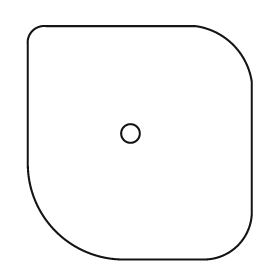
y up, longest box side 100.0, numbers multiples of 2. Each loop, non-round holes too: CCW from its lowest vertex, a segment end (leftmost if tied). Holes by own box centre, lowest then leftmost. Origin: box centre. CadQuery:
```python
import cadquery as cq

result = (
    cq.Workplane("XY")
    .moveTo(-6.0, -50.0)
    .lineTo(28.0, -50.0)
    .threePointArc((42.0, -44.0), (48.0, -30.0))
    .lineTo(48.0, 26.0)
    .threePointArc((40.0, 42.0), (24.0, 50.0))
    .lineTo(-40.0, 50.0)
    .threePointArc((-46.0, 48.0), (-48.0, 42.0))
    .lineTo(-48.0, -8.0)
    .threePointArc((-36.0, -38.0), (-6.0, -50.0))
    .close()
    .moveTo(-4.0, 4.0)
    .circle(4.0)
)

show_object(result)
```